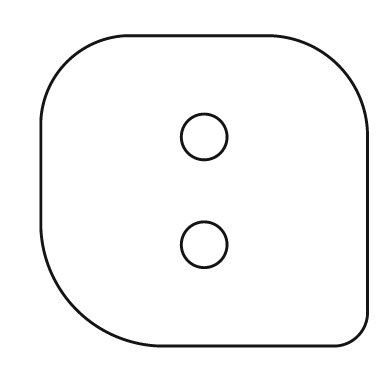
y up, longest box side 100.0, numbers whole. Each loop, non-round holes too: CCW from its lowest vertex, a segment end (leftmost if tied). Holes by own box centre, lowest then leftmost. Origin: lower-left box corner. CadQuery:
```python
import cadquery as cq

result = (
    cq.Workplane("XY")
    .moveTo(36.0, 0.0)
    .lineTo(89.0, 0.0)
    .threePointArc((97.0, 3.0), (100.0, 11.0))
    .lineTo(100.0, 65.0)
    .threePointArc((91.0, 86.0), (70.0, 95.0))
    .lineTo(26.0, 95.0)
    .threePointArc((8.0, 87.0), (0.0, 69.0))
    .lineTo(0.0, 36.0)
    .threePointArc((11.0, 11.0), (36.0, 0.0))
    .close()
    .moveTo(50.0, 31.0)
    .circle(7.0)
    .moveTo(50.0, 64.0)
    .circle(7.0)
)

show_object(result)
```